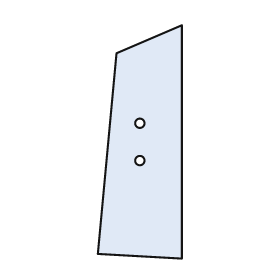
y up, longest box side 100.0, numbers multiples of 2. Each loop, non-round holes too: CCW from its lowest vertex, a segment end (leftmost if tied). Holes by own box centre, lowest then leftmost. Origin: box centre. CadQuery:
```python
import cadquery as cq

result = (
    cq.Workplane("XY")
    .moveTo(18.0, -50.0)
    .lineTo(18.0, 50.0)
    .lineTo(-10.0, 38.0)
    .lineTo(-18.0, -48.0)
    .close()
    .moveTo(0.0, -8.0)
    .circle(2.0)
    .moveTo(0.0, 8.0)
    .circle(2.0)
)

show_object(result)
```